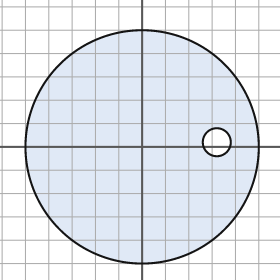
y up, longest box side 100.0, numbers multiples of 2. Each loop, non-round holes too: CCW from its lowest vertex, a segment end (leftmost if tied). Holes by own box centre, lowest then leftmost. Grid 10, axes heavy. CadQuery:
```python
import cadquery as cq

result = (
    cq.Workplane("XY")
    .moveTo(0.0, 0.0)
    .circle(50.0)
    .moveTo(32.0, 2.0)
    .circle(6.0)
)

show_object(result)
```